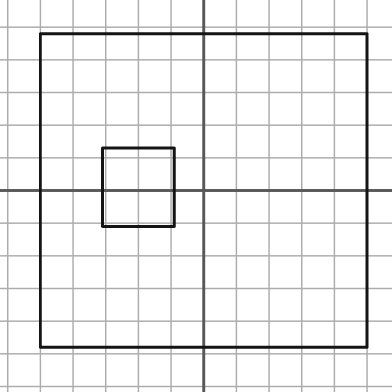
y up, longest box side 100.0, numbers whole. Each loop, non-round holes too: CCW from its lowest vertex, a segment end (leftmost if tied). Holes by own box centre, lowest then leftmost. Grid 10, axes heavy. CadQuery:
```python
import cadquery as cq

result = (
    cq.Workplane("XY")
    .moveTo(-50.0, -48.0)
    .lineTo(50.0, -48.0)
    .lineTo(50.0, 48.0)
    .lineTo(-50.0, 48.0)
    .close()
    .moveTo(-31.0, -11.0)
    .lineTo(-9.0, -11.0)
    .lineTo(-9.0, 13.0)
    .lineTo(-31.0, 13.0)
    .close()
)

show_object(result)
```